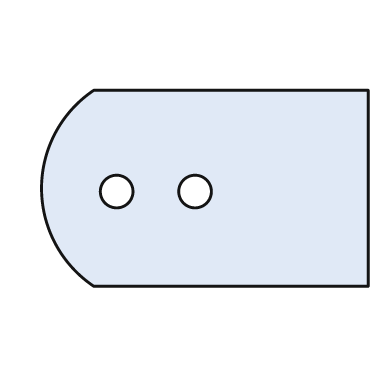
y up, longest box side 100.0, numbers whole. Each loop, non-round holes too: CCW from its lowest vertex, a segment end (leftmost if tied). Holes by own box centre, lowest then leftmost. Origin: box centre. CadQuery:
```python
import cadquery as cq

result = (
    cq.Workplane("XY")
    .moveTo(-34.0, -30.0)
    .lineTo(50.0, -30.0)
    .lineTo(50.0, 30.0)
    .lineTo(-34.0, 30.0)
    .threePointArc((-50.0, 0.0), (-34.0, -30.0))
    .close()
    .moveTo(-27.0, -1.0)
    .circle(5.0)
    .moveTo(-3.0, -1.0)
    .circle(5.0)
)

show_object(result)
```